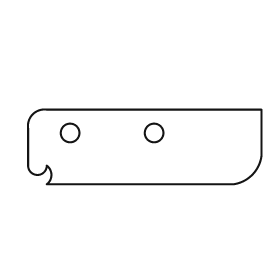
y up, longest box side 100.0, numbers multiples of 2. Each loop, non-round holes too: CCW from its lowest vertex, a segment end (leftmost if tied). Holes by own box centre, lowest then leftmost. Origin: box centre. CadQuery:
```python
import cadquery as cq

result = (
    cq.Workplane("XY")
    .moveTo(-42.0, -16.0)
    .lineTo(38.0, -16.0)
    .threePointArc((46.0, -12.0), (50.0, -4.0))
    .lineTo(50.0, 16.0)
    .lineTo(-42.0, 16.0)
    .threePointArc((-48.0, 14.0), (-50.0, 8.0))
    .lineTo(-50.0, -8.0)
    .threePointArc((-46.0, -12.0), (-42.0, -8.0))
    .threePointArc((-40.0, -12.0), (-42.0, -16.0))
    .close()
    .moveTo(-32.0, 6.0)
    .circle(4.0)
    .moveTo(4.0, 6.0)
    .circle(4.0)
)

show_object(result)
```